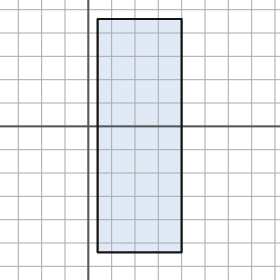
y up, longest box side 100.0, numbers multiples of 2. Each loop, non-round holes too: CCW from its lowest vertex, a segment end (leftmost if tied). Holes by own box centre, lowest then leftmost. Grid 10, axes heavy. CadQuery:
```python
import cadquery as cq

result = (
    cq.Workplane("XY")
    .moveTo(4.0, -54.0)
    .lineTo(40.0, -54.0)
    .lineTo(40.0, 46.0)
    .lineTo(4.0, 46.0)
    .close()
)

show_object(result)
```